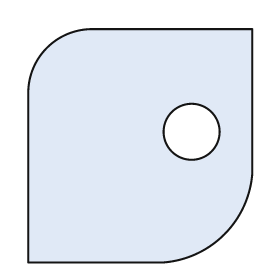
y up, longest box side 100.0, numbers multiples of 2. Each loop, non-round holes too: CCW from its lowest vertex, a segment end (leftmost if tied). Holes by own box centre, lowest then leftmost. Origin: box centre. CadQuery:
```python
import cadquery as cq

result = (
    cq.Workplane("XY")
    .moveTo(-48.0, -50.0)
    .lineTo(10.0, -50.0)
    .threePointArc((36.0, -38.0), (48.0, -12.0))
    .lineTo(48.0, 50.0)
    .lineTo(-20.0, 50.0)
    .threePointArc((-40.0, 42.0), (-48.0, 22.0))
    .close()
    .moveTo(22.0, 6.0)
    .circle(12.0)
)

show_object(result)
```